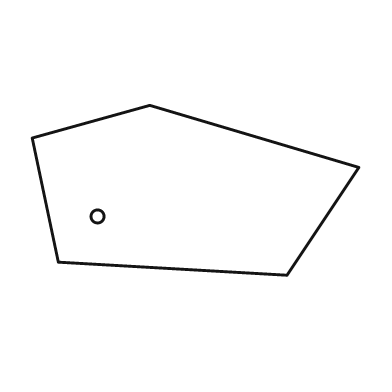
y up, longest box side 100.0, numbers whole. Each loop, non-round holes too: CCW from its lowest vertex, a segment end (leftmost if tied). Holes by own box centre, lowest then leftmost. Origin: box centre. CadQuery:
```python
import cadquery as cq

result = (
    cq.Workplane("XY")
    .moveTo(28.0, -26.0)
    .lineTo(50.0, 7.0)
    .lineTo(-14.0, 26.0)
    .lineTo(-50.0, 16.0)
    .lineTo(-42.0, -22.0)
    .close()
    .moveTo(-30.0, -8.0)
    .circle(2.0)
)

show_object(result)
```